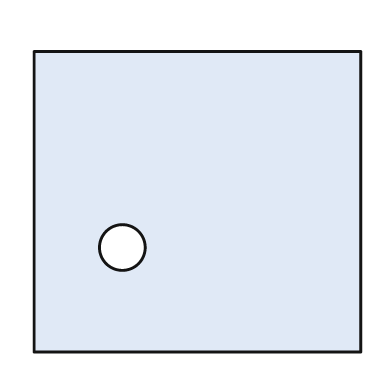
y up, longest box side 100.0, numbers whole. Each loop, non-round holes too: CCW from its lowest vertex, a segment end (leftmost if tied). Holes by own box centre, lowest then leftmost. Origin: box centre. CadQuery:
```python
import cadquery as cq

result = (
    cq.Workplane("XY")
    .moveTo(-50.0, -46.0)
    .lineTo(50.0, -46.0)
    .lineTo(50.0, 46.0)
    .lineTo(-50.0, 46.0)
    .close()
    .moveTo(-23.0, -14.0)
    .circle(7.0)
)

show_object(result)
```